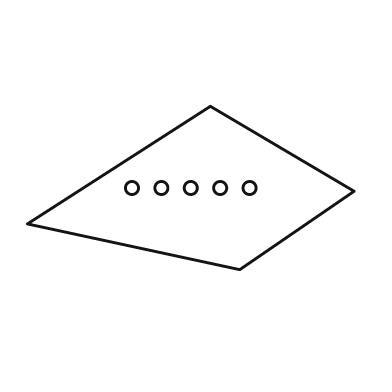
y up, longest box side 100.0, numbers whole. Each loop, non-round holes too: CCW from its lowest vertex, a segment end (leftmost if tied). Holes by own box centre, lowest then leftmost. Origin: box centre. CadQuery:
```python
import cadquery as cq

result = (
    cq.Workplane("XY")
    .moveTo(15.0, -25.0)
    .lineTo(50.0, -1.0)
    .lineTo(6.0, 25.0)
    .lineTo(-50.0, -11.0)
    .close()
    .moveTo(-18.0, 0.0)
    .circle(2.0)
    .moveTo(-9.0, 0.0)
    .circle(2.0)
    .moveTo(0.0, 0.0)
    .circle(2.0)
    .moveTo(9.0, 0.0)
    .circle(2.0)
    .moveTo(18.0, 0.0)
    .circle(2.0)
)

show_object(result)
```